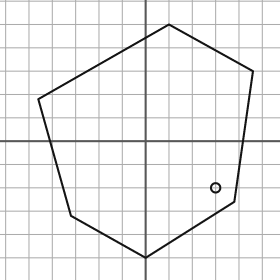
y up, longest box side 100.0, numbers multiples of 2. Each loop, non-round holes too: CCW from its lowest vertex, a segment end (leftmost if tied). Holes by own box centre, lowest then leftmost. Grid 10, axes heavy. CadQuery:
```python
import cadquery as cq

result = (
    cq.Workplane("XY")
    .moveTo(0.0, -50.0)
    .lineTo(38.0, -26.0)
    .lineTo(46.0, 30.0)
    .lineTo(10.0, 50.0)
    .lineTo(-46.0, 18.0)
    .lineTo(-32.0, -32.0)
    .close()
    .moveTo(30.0, -20.0)
    .circle(2.0)
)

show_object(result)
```